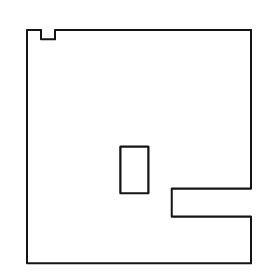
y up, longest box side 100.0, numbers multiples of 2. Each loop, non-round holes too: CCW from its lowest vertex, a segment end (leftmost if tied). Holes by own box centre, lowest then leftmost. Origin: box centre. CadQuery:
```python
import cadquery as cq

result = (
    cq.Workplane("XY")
    .moveTo(-48.0, -50.0)
    .lineTo(48.0, -50.0)
    .lineTo(48.0, -30.0)
    .lineTo(14.0, -30.0)
    .lineTo(14.0, -18.0)
    .lineTo(48.0, -18.0)
    .lineTo(48.0, 50.0)
    .lineTo(-36.0, 50.0)
    .lineTo(-36.0, 46.0)
    .lineTo(-42.0, 46.0)
    .lineTo(-42.0, 50.0)
    .lineTo(-48.0, 50.0)
    .close()
    .moveTo(-8.0, -20.0)
    .lineTo(4.0, -20.0)
    .lineTo(4.0, 0.0)
    .lineTo(-8.0, 0.0)
    .close()
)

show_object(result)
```